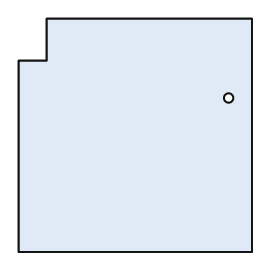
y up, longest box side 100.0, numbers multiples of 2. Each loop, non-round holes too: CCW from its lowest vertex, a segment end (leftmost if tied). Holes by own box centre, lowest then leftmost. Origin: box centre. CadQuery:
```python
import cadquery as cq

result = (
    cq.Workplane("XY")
    .moveTo(-50.0, -50.0)
    .lineTo(50.0, -50.0)
    .lineTo(50.0, 50.0)
    .lineTo(-38.0, 50.0)
    .lineTo(-38.0, 32.0)
    .lineTo(-50.0, 32.0)
    .close()
    .moveTo(40.0, 16.0)
    .circle(2.0)
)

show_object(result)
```